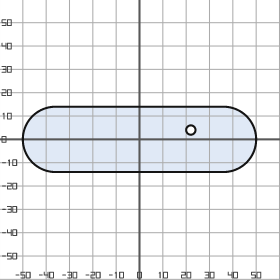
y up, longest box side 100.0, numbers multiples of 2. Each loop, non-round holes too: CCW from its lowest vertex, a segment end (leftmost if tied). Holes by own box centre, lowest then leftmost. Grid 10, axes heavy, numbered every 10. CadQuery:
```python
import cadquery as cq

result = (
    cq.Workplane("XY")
    .moveTo(-36.0, -14.0)
    .lineTo(36.0, -14.0)
    .threePointArc((50.0, 0.0), (36.0, 14.0))
    .lineTo(-36.0, 14.0)
    .threePointArc((-50.0, 0.0), (-36.0, -14.0))
    .close()
    .moveTo(22.0, 4.0)
    .circle(2.0)
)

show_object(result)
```